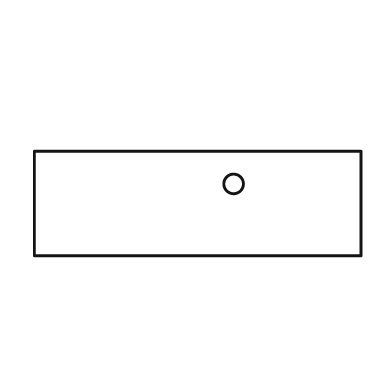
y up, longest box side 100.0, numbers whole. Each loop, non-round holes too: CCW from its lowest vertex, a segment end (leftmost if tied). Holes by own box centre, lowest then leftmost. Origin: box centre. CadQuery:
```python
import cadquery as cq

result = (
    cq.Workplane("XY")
    .moveTo(-50.0, -16.0)
    .lineTo(50.0, -16.0)
    .lineTo(50.0, 16.0)
    .lineTo(-50.0, 16.0)
    .close()
    .moveTo(11.0, 6.0)
    .circle(3.0)
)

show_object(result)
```